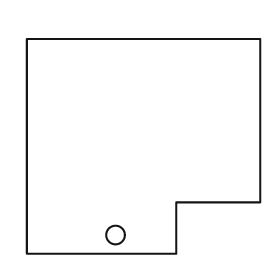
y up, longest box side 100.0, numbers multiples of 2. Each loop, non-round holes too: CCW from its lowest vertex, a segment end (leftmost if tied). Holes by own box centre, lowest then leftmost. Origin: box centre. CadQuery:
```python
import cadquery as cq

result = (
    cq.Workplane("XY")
    .moveTo(-50.0, -46.0)
    .lineTo(14.0, -46.0)
    .lineTo(14.0, -24.0)
    .lineTo(50.0, -24.0)
    .lineTo(50.0, 46.0)
    .lineTo(-50.0, 46.0)
    .close()
    .moveTo(-12.0, -38.0)
    .circle(4.0)
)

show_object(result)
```